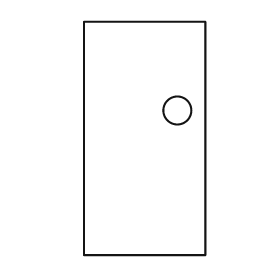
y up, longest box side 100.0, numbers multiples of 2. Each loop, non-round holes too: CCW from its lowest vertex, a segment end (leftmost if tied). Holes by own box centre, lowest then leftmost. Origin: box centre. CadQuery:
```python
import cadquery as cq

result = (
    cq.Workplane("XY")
    .moveTo(-26.0, -50.0)
    .lineTo(26.0, -50.0)
    .lineTo(26.0, 50.0)
    .lineTo(-26.0, 50.0)
    .close()
    .moveTo(14.0, 12.0)
    .circle(6.0)
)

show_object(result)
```